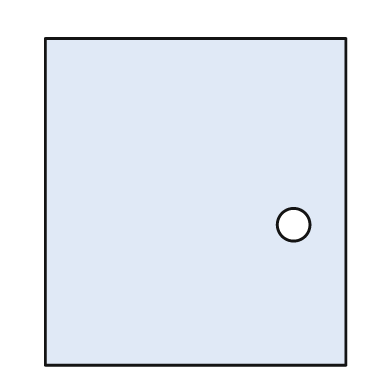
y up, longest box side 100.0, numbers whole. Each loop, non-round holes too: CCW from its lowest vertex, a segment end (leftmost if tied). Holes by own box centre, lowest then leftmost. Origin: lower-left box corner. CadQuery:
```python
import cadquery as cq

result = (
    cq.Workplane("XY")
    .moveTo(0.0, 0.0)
    .lineTo(92.0, 0.0)
    .lineTo(92.0, 100.0)
    .lineTo(0.0, 100.0)
    .close()
    .moveTo(76.0, 43.0)
    .circle(5.0)
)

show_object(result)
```